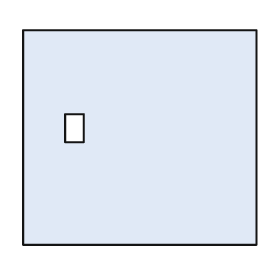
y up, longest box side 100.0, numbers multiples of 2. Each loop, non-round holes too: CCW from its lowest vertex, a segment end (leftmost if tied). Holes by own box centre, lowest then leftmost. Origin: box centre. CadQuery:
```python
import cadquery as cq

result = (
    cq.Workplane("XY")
    .moveTo(-50.0, -46.0)
    .lineTo(50.0, -46.0)
    .lineTo(50.0, 46.0)
    .lineTo(-50.0, 46.0)
    .close()
    .moveTo(-32.0, -2.0)
    .lineTo(-24.0, -2.0)
    .lineTo(-24.0, 10.0)
    .lineTo(-32.0, 10.0)
    .close()
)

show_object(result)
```